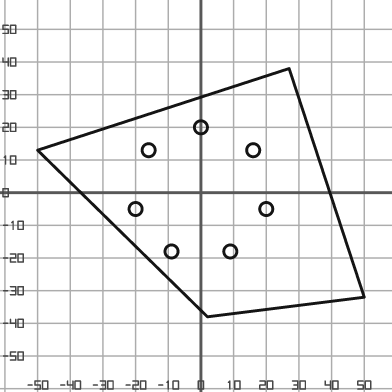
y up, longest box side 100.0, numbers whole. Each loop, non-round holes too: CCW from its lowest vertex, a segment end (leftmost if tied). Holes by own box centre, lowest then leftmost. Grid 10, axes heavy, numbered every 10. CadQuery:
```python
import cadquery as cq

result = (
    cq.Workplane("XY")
    .moveTo(2.0, -38.0)
    .lineTo(50.0, -32.0)
    .lineTo(27.0, 38.0)
    .lineTo(-50.0, 13.0)
    .close()
    .moveTo(-9.0, -18.0)
    .circle(2.0)
    .moveTo(9.0, -18.0)
    .circle(2.0)
    .moveTo(-20.0, -5.0)
    .circle(2.0)
    .moveTo(20.0, -5.0)
    .circle(2.0)
    .moveTo(-16.0, 13.0)
    .circle(2.0)
    .moveTo(16.0, 13.0)
    .circle(2.0)
    .moveTo(0.0, 20.0)
    .circle(2.0)
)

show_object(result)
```